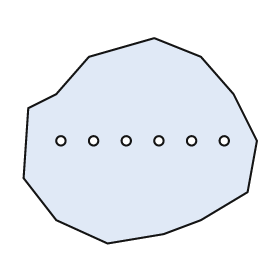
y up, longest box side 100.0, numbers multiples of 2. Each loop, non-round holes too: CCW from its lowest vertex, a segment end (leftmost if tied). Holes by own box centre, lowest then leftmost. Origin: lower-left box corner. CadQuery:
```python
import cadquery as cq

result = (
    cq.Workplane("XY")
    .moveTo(36.0, 0.0)
    .lineTo(60.0, 4.0)
    .lineTo(76.0, 10.0)
    .lineTo(96.0, 22.0)
    .lineTo(100.0, 44.0)
    .lineTo(90.0, 64.0)
    .lineTo(76.0, 80.0)
    .lineTo(56.0, 88.0)
    .lineTo(28.0, 80.0)
    .lineTo(14.0, 64.0)
    .lineTo(2.0, 58.0)
    .lineTo(0.0, 28.0)
    .lineTo(14.0, 10.0)
    .close()
    .moveTo(16.0, 44.0)
    .circle(2.0)
    .moveTo(30.0, 44.0)
    .circle(2.0)
    .moveTo(44.0, 44.0)
    .circle(2.0)
    .moveTo(58.0, 44.0)
    .circle(2.0)
    .moveTo(72.0, 44.0)
    .circle(2.0)
    .moveTo(86.0, 44.0)
    .circle(2.0)
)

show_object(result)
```